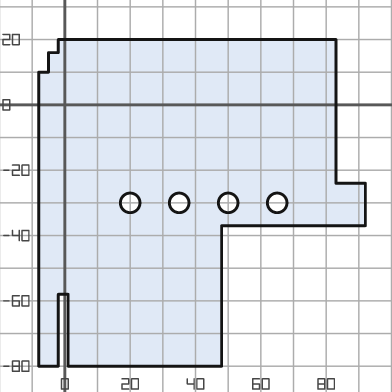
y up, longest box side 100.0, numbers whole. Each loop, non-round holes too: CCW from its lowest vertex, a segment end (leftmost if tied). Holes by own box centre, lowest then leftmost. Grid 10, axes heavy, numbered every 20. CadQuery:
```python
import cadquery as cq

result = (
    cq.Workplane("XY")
    .moveTo(-8.0, -80.0)
    .lineTo(-2.0, -80.0)
    .lineTo(-2.0, -58.0)
    .lineTo(1.0, -58.0)
    .lineTo(1.0, -80.0)
    .lineTo(48.0, -80.0)
    .lineTo(48.0, -37.0)
    .lineTo(92.0, -37.0)
    .lineTo(92.0, -24.0)
    .lineTo(83.0, -24.0)
    .lineTo(83.0, 20.0)
    .lineTo(-2.0, 20.0)
    .lineTo(-2.0, 16.0)
    .lineTo(-5.0, 16.0)
    .lineTo(-5.0, 10.0)
    .lineTo(-8.0, 10.0)
    .close()
    .moveTo(20.0, -30.0)
    .circle(3.0)
    .moveTo(35.0, -30.0)
    .circle(3.0)
    .moveTo(50.0, -30.0)
    .circle(3.0)
    .moveTo(65.0, -30.0)
    .circle(3.0)
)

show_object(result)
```